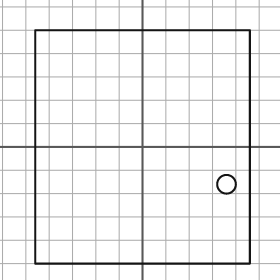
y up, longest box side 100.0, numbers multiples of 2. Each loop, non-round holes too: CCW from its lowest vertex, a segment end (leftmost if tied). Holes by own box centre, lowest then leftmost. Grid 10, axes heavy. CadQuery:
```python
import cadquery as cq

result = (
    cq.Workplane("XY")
    .moveTo(-46.0, -50.0)
    .lineTo(46.0, -50.0)
    .lineTo(46.0, 50.0)
    .lineTo(-46.0, 50.0)
    .close()
    .moveTo(36.0, -16.0)
    .circle(4.0)
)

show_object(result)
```